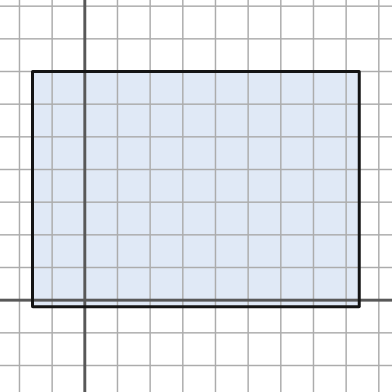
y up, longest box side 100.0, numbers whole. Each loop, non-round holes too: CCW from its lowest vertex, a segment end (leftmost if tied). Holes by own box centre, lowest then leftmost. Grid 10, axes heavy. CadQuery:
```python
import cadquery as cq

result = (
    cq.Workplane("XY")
    .moveTo(-16.0, -2.0)
    .lineTo(84.0, -2.0)
    .lineTo(84.0, 70.0)
    .lineTo(-16.0, 70.0)
    .close()
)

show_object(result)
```